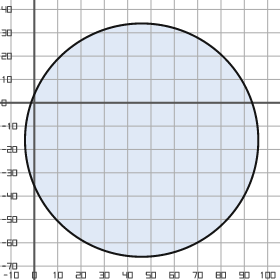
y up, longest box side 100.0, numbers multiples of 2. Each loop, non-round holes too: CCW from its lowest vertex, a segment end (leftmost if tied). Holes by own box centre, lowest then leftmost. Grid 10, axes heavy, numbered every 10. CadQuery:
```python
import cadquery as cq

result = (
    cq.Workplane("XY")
    .moveTo(46.0, -16.0)
    .circle(50.0)
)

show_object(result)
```